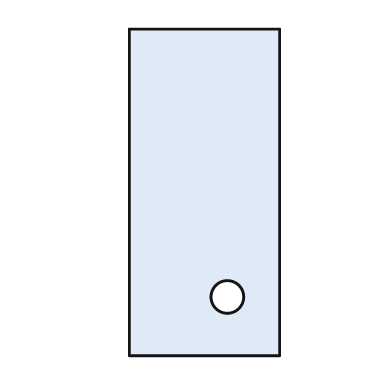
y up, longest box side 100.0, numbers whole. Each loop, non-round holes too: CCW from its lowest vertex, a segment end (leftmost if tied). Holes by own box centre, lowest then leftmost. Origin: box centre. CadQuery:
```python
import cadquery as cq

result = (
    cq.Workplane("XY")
    .moveTo(-23.0, -50.0)
    .lineTo(23.0, -50.0)
    .lineTo(23.0, 50.0)
    .lineTo(-23.0, 50.0)
    .close()
    .moveTo(7.0, -32.0)
    .circle(5.0)
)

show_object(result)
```